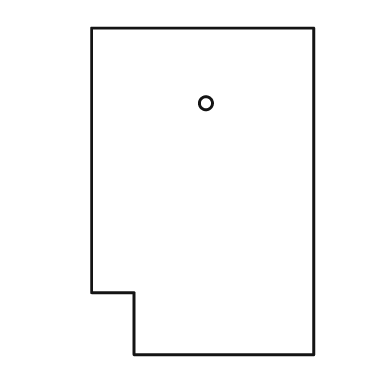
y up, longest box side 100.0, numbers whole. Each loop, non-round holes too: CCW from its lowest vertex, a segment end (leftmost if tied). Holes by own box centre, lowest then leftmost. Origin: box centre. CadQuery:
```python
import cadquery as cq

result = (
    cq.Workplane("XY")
    .moveTo(-21.0, -50.0)
    .lineTo(34.0, -50.0)
    .lineTo(34.0, 50.0)
    .lineTo(-34.0, 50.0)
    .lineTo(-34.0, -31.0)
    .lineTo(-21.0, -31.0)
    .close()
    .moveTo(1.0, 27.0)
    .circle(2.0)
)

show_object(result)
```